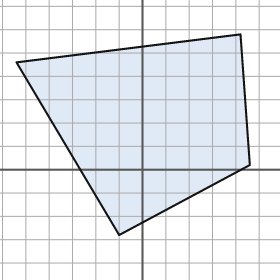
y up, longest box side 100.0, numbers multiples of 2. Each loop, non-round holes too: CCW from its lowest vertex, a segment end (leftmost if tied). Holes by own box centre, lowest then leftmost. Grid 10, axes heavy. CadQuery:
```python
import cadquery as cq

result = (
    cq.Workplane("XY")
    .moveTo(-10.0, -28.0)
    .lineTo(46.0, 2.0)
    .lineTo(42.0, 58.0)
    .lineTo(-54.0, 46.0)
    .close()
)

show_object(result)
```